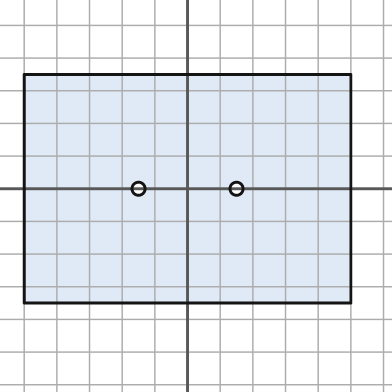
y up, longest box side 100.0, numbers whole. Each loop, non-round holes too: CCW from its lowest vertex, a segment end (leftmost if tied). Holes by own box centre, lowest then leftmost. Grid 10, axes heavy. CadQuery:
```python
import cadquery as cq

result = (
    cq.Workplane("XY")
    .moveTo(-50.0, -35.0)
    .lineTo(50.0, -35.0)
    .lineTo(50.0, 35.0)
    .lineTo(-50.0, 35.0)
    .close()
    .moveTo(-15.0, 0.0)
    .circle(2.0)
    .moveTo(15.0, 0.0)
    .circle(2.0)
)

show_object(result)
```